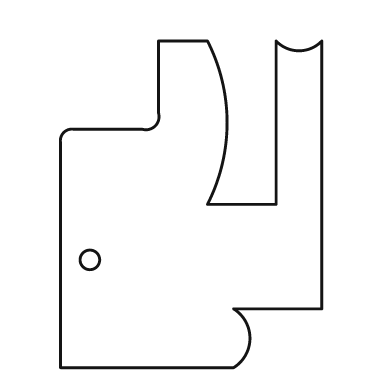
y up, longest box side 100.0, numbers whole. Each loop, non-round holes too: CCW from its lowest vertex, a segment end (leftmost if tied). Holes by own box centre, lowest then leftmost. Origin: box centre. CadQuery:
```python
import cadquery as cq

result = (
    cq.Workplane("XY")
    .moveTo(-40.0, -50.0)
    .lineTo(13.0, -50.0)
    .threePointArc((18.0, -41.0), (13.0, -32.0))
    .lineTo(40.0, -32.0)
    .lineTo(40.0, 50.0)
    .threePointArc((33.0, 47.0), (26.0, 50.0))
    .lineTo(26.0, 0.0)
    .lineTo(5.0, 0.0)
    .threePointArc((11.0, 25.0), (5.0, 50.0))
    .lineTo(-10.0, 50.0)
    .lineTo(-10.0, 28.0)
    .threePointArc((-11.0, 24.0), (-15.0, 23.0))
    .lineTo(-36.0, 23.0)
    .threePointArc((-39.0, 22.0), (-40.0, 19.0))
    .close()
    .moveTo(-31.0, -17.0)
    .circle(3.0)
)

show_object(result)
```